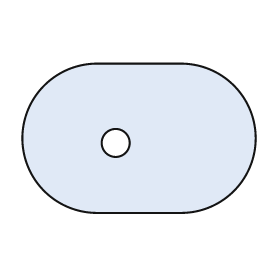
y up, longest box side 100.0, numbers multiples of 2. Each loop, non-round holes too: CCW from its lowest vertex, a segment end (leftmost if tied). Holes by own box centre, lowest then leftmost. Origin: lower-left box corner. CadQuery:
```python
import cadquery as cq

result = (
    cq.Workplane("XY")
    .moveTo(32.0, 0.0)
    .lineTo(68.0, 0.0)
    .threePointArc((100.0, 32.0), (68.0, 64.0))
    .lineTo(32.0, 64.0)
    .threePointArc((0.0, 32.0), (32.0, 0.0))
    .close()
    .moveTo(40.0, 30.0)
    .circle(6.0)
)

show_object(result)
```